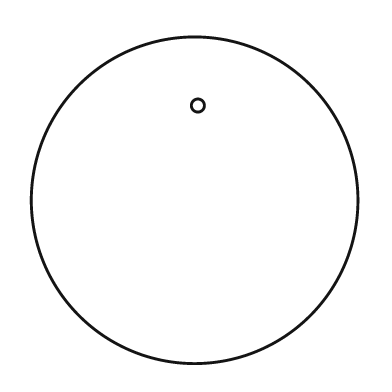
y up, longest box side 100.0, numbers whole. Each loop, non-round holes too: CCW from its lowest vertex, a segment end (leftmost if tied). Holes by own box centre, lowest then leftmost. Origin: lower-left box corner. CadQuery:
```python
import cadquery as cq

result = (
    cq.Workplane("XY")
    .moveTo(50.0, 50.0)
    .circle(50.0)
    .moveTo(51.0, 79.0)
    .circle(2.0)
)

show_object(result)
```